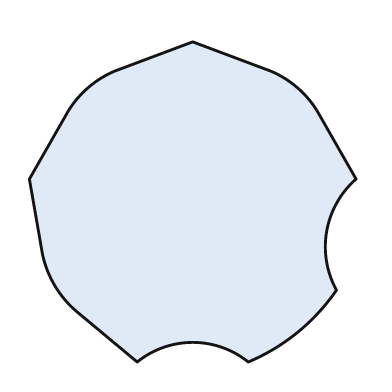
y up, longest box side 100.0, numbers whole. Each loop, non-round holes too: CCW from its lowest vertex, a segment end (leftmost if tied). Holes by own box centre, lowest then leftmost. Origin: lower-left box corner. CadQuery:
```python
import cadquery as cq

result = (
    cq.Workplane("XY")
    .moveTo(33.0, 0.0)
    .threePointArc((50.0, 6.0), (67.0, 0.0))
    .threePointArc((82.0, 9.0), (94.0, 22.0))
    .threePointArc((91.0, 40.0), (100.0, 56.0))
    .lineTo(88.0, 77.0)
    .threePointArc((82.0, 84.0), (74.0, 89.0))
    .lineTo(50.0, 98.0)
    .lineTo(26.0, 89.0)
    .threePointArc((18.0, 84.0), (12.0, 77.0))
    .lineTo(0.0, 56.0)
    .lineTo(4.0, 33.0)
    .threePointArc((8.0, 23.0), (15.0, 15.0))
    .close()
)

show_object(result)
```